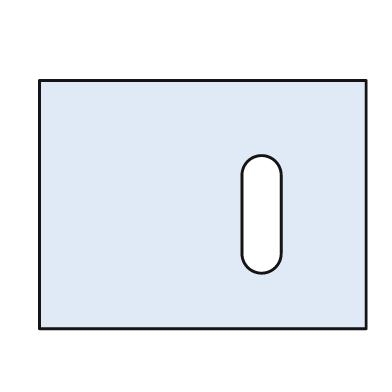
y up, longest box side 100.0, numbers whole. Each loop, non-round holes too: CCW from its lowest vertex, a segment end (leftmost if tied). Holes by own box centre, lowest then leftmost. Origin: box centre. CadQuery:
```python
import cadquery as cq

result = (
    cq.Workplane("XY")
    .moveTo(-50.0, -38.0)
    .lineTo(50.0, -38.0)
    .lineTo(50.0, 38.0)
    .lineTo(-50.0, 38.0)
    .close()
    .moveTo(12.0, -15.0)
    .threePointArc((18.0, -21.0), (24.0, -15.0))
    .lineTo(24.0, 9.0)
    .threePointArc((18.0, 15.0), (12.0, 9.0))
    .close()
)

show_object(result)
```